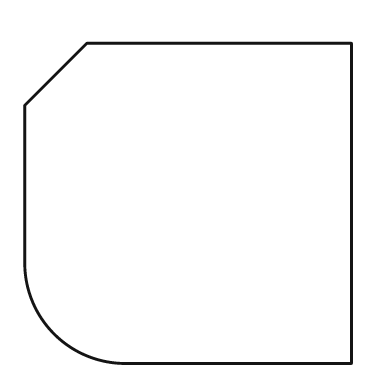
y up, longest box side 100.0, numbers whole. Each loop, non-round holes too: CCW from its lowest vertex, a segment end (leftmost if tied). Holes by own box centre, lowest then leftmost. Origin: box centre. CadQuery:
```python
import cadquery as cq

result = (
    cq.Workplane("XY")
    .moveTo(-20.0, -49.0)
    .lineTo(50.0, -49.0)
    .lineTo(50.0, 49.0)
    .lineTo(-31.0, 49.0)
    .lineTo(-50.0, 30.0)
    .lineTo(-50.0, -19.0)
    .threePointArc((-41.0, -40.0), (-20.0, -49.0))
    .close()
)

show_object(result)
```